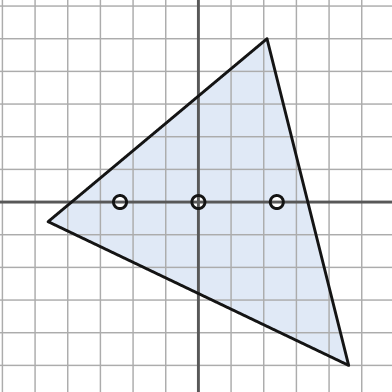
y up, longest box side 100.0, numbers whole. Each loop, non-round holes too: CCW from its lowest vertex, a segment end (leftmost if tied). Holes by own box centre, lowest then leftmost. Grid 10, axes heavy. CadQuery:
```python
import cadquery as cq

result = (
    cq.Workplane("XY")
    .moveTo(46.0, -50.0)
    .lineTo(21.0, 50.0)
    .lineTo(-46.0, -6.0)
    .close()
    .moveTo(-24.0, 0.0)
    .circle(2.0)
    .moveTo(0.0, 0.0)
    .circle(2.0)
    .moveTo(24.0, 0.0)
    .circle(2.0)
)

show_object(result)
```